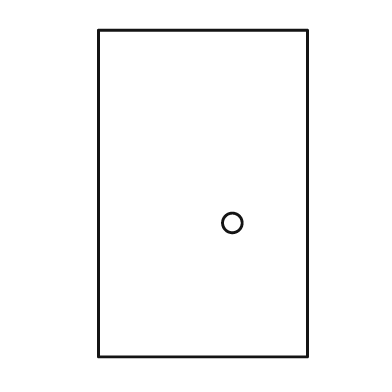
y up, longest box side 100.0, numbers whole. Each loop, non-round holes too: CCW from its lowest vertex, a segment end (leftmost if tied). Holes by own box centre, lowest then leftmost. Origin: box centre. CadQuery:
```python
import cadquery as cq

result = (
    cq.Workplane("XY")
    .moveTo(-32.0, -50.0)
    .lineTo(32.0, -50.0)
    .lineTo(32.0, 50.0)
    .lineTo(-32.0, 50.0)
    .close()
    .moveTo(9.0, -9.0)
    .circle(3.0)
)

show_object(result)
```